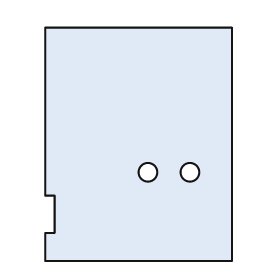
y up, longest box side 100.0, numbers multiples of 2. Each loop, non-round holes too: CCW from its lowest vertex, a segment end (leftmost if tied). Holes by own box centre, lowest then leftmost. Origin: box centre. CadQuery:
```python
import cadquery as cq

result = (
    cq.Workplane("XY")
    .moveTo(-40.0, -50.0)
    .lineTo(40.0, -50.0)
    .lineTo(40.0, 50.0)
    .lineTo(-40.0, 50.0)
    .lineTo(-40.0, -22.0)
    .lineTo(-36.0, -22.0)
    .lineTo(-36.0, -38.0)
    .lineTo(-40.0, -38.0)
    .close()
    .moveTo(4.0, -12.0)
    .circle(4.0)
    .moveTo(22.0, -12.0)
    .circle(4.0)
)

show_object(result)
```